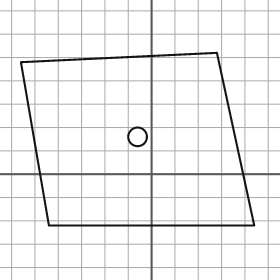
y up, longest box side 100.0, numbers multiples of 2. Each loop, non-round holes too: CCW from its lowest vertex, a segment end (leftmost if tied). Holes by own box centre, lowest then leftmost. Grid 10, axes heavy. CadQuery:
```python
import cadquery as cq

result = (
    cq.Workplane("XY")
    .moveTo(-44.0, -22.0)
    .lineTo(44.0, -22.0)
    .lineTo(28.0, 52.0)
    .lineTo(-56.0, 48.0)
    .close()
    .moveTo(-6.0, 16.0)
    .circle(4.0)
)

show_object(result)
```